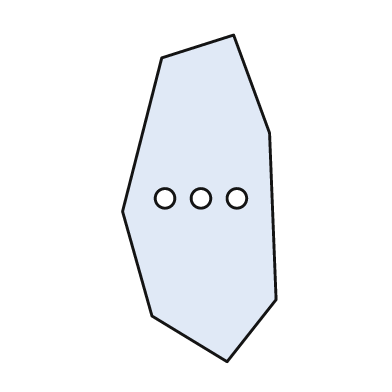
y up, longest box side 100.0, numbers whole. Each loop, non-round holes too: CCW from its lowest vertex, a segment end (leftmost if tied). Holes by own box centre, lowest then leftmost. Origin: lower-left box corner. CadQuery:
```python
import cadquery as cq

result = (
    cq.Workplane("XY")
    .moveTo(32.0, 0.0)
    .lineTo(47.0, 19.0)
    .lineTo(45.0, 70.0)
    .lineTo(34.0, 100.0)
    .lineTo(12.0, 93.0)
    .lineTo(0.0, 46.0)
    .lineTo(9.0, 14.0)
    .close()
    .moveTo(13.0, 50.0)
    .circle(3.0)
    .moveTo(24.0, 50.0)
    .circle(3.0)
    .moveTo(35.0, 50.0)
    .circle(3.0)
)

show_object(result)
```